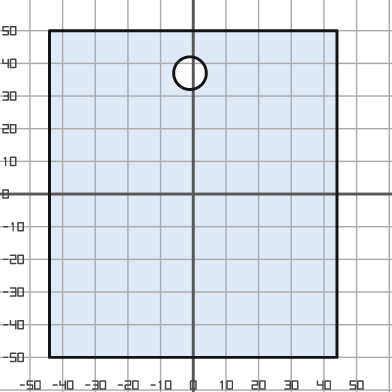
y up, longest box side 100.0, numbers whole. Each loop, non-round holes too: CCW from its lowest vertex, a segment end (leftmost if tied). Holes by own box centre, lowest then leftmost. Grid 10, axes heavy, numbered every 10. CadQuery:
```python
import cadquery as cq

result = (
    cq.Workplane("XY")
    .moveTo(-44.0, -50.0)
    .lineTo(44.0, -50.0)
    .lineTo(44.0, 50.0)
    .lineTo(-44.0, 50.0)
    .close()
    .moveTo(-1.0, 37.0)
    .circle(5.0)
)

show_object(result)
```